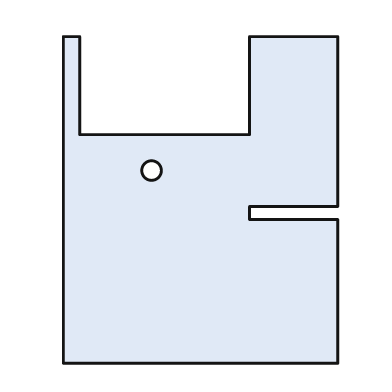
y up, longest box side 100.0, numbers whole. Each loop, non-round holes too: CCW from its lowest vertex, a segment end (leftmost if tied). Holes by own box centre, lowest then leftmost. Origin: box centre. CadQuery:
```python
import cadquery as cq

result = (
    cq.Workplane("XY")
    .moveTo(-42.0, -50.0)
    .lineTo(42.0, -50.0)
    .lineTo(42.0, -6.0)
    .lineTo(15.0, -6.0)
    .lineTo(15.0, -2.0)
    .lineTo(42.0, -2.0)
    .lineTo(42.0, 50.0)
    .lineTo(15.0, 50.0)
    .lineTo(15.0, 20.0)
    .lineTo(-37.0, 20.0)
    .lineTo(-37.0, 50.0)
    .lineTo(-42.0, 50.0)
    .close()
    .moveTo(-15.0, 9.0)
    .circle(3.0)
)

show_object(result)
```